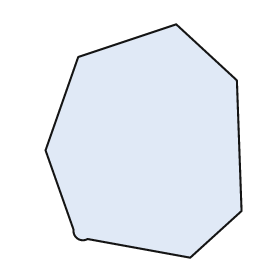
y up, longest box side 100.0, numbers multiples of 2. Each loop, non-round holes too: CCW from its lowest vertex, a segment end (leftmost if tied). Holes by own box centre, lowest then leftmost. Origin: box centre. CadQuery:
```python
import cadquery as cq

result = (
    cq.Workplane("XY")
    .moveTo(20.0, -50.0)
    .lineTo(42.0, -30.0)
    .lineTo(40.0, 26.0)
    .lineTo(14.0, 50.0)
    .lineTo(-28.0, 36.0)
    .lineTo(-42.0, -4.0)
    .lineTo(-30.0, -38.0)
    .threePointArc((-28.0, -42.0), (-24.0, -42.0))
    .close()
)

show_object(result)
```